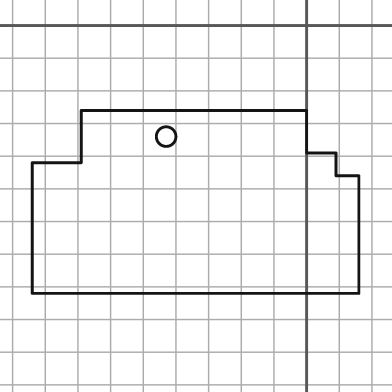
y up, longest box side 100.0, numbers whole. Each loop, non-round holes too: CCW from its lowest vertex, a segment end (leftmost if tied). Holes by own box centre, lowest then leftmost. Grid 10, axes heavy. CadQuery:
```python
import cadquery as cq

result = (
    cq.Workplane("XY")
    .moveTo(-84.0, -82.0)
    .lineTo(16.0, -82.0)
    .lineTo(16.0, -46.0)
    .lineTo(9.0, -46.0)
    .lineTo(9.0, -39.0)
    .lineTo(0.0, -39.0)
    .lineTo(0.0, -26.0)
    .lineTo(-69.0, -26.0)
    .lineTo(-69.0, -42.0)
    .lineTo(-84.0, -42.0)
    .close()
    .moveTo(-43.0, -34.0)
    .circle(3.0)
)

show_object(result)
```